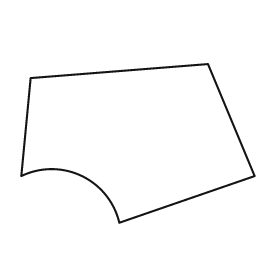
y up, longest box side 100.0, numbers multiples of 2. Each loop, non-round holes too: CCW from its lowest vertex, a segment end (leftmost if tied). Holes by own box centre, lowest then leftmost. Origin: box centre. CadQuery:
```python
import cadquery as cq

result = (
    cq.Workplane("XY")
    .moveTo(-8.0, -34.0)
    .lineTo(50.0, -14.0)
    .lineTo(30.0, 34.0)
    .lineTo(-46.0, 28.0)
    .lineTo(-50.0, -14.0)
    .threePointArc((-24.0, -14.0), (-8.0, -34.0))
    .close()
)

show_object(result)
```